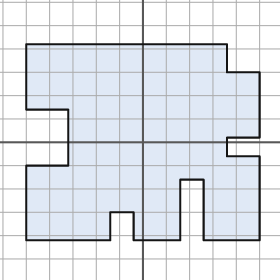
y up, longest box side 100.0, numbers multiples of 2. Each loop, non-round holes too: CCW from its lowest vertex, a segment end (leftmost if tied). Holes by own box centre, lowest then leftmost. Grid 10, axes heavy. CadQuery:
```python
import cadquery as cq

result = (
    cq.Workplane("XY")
    .moveTo(-50.0, -42.0)
    .lineTo(-14.0, -42.0)
    .lineTo(-14.0, -30.0)
    .lineTo(-4.0, -30.0)
    .lineTo(-4.0, -42.0)
    .lineTo(16.0, -42.0)
    .lineTo(16.0, -16.0)
    .lineTo(26.0, -16.0)
    .lineTo(26.0, -42.0)
    .lineTo(50.0, -42.0)
    .lineTo(50.0, -6.0)
    .lineTo(36.0, -6.0)
    .lineTo(36.0, 2.0)
    .lineTo(50.0, 2.0)
    .lineTo(50.0, 30.0)
    .lineTo(36.0, 30.0)
    .lineTo(36.0, 42.0)
    .lineTo(-50.0, 42.0)
    .lineTo(-50.0, 14.0)
    .lineTo(-32.0, 14.0)
    .lineTo(-32.0, -10.0)
    .lineTo(-50.0, -10.0)
    .close()
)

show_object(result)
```